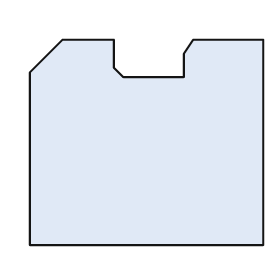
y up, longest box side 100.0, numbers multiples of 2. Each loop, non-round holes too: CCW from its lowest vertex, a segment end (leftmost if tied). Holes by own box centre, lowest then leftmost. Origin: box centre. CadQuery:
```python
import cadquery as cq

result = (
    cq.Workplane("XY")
    .moveTo(-50.0, -44.0)
    .lineTo(50.0, -44.0)
    .lineTo(50.0, 44.0)
    .lineTo(20.0, 44.0)
    .lineTo(16.0, 38.0)
    .lineTo(16.0, 28.0)
    .lineTo(-10.0, 28.0)
    .lineTo(-14.0, 32.0)
    .lineTo(-14.0, 44.0)
    .lineTo(-36.0, 44.0)
    .lineTo(-50.0, 30.0)
    .close()
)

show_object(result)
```